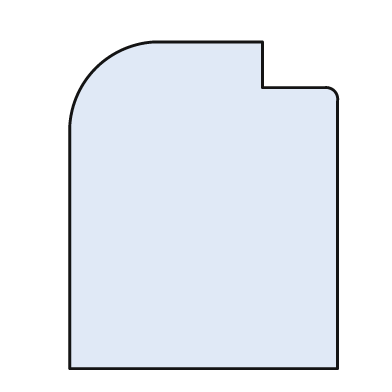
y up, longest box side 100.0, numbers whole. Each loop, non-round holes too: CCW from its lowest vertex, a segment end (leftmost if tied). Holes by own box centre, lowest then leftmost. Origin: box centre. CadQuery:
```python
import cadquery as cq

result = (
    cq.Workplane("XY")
    .moveTo(-41.0, -50.0)
    .lineTo(41.0, -50.0)
    .lineTo(41.0, 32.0)
    .threePointArc((40.0, 35.0), (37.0, 36.0))
    .lineTo(18.0, 36.0)
    .lineTo(18.0, 50.0)
    .lineTo(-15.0, 50.0)
    .threePointArc((-33.0, 42.0), (-41.0, 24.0))
    .close()
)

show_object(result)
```